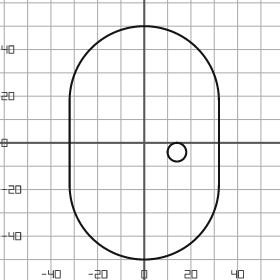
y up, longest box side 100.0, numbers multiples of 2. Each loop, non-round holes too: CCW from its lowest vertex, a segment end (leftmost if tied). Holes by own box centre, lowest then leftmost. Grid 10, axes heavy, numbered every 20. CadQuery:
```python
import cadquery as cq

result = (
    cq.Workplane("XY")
    .moveTo(-32.0, -18.0)
    .threePointArc((0.0, -50.0), (32.0, -18.0))
    .lineTo(32.0, 18.0)
    .threePointArc((0.0, 50.0), (-32.0, 18.0))
    .close()
    .moveTo(14.0, -4.0)
    .circle(4.0)
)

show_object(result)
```